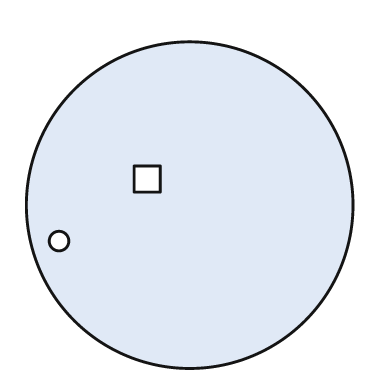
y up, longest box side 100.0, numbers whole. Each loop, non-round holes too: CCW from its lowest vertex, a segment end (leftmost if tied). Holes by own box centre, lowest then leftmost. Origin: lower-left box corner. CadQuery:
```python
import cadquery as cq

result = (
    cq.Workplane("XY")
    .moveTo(50.0, 50.0)
    .circle(50.0)
    .moveTo(10.0, 39.0)
    .circle(3.0)
    .moveTo(33.0, 54.0)
    .lineTo(41.0, 54.0)
    .lineTo(41.0, 62.0)
    .lineTo(33.0, 62.0)
    .close()
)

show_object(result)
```